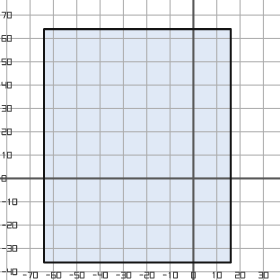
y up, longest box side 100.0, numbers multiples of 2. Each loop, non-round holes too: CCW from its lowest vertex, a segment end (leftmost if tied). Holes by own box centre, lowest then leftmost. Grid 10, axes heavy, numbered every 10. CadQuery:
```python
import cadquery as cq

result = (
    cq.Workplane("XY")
    .moveTo(-64.0, -36.0)
    .lineTo(16.0, -36.0)
    .lineTo(16.0, 64.0)
    .lineTo(-64.0, 64.0)
    .close()
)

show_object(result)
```